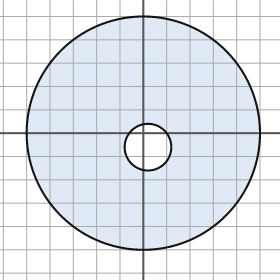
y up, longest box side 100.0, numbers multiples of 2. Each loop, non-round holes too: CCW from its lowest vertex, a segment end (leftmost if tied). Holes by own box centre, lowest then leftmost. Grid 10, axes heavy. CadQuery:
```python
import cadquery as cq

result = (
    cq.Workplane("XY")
    .moveTo(0.0, 0.0)
    .circle(50.0)
    .moveTo(2.0, -6.0)
    .circle(10.0)
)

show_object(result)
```